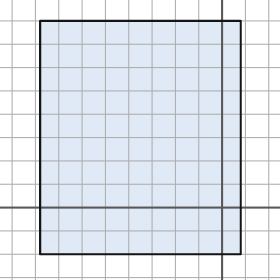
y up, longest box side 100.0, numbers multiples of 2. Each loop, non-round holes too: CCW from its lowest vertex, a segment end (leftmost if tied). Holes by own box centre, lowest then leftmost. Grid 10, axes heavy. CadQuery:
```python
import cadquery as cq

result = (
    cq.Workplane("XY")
    .moveTo(-78.0, -20.0)
    .lineTo(8.0, -20.0)
    .lineTo(8.0, 80.0)
    .lineTo(-78.0, 80.0)
    .close()
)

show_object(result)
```